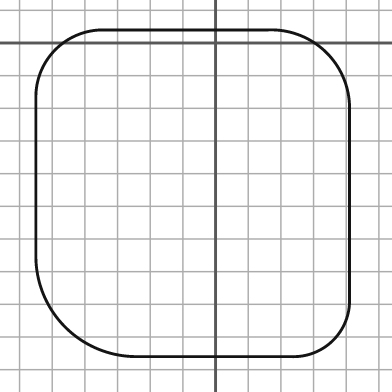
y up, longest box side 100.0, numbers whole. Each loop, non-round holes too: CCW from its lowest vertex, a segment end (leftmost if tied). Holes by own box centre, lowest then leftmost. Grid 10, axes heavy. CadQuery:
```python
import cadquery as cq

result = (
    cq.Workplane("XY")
    .moveTo(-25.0, -96.0)
    .lineTo(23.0, -96.0)
    .threePointArc((36.0, -91.0), (41.0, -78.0))
    .lineTo(41.0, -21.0)
    .threePointArc((34.0, -3.0), (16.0, 4.0))
    .lineTo(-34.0, 4.0)
    .threePointArc((-49.0, -2.0), (-55.0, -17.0))
    .lineTo(-55.0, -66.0)
    .threePointArc((-46.0, -87.0), (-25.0, -96.0))
    .close()
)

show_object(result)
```